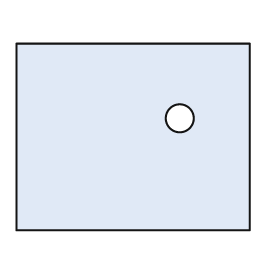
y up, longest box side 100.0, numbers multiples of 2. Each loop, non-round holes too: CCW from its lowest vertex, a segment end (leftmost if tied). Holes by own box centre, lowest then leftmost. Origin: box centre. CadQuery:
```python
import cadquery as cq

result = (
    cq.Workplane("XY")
    .moveTo(-50.0, -40.0)
    .lineTo(50.0, -40.0)
    .lineTo(50.0, 40.0)
    .lineTo(-50.0, 40.0)
    .close()
    .moveTo(20.0, 8.0)
    .circle(6.0)
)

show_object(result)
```